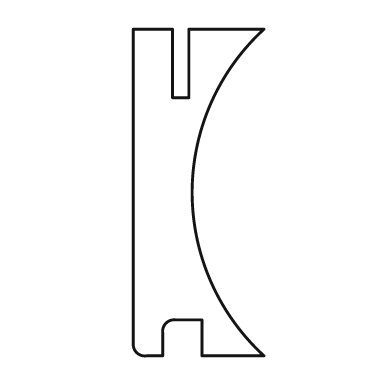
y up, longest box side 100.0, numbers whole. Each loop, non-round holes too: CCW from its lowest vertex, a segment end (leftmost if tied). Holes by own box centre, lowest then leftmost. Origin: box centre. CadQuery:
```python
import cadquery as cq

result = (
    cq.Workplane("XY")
    .moveTo(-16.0, -50.0)
    .lineTo(-11.0, -50.0)
    .lineTo(-11.0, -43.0)
    .threePointArc((-10.0, -40.0), (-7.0, -39.0))
    .lineTo(1.0, -39.0)
    .lineTo(1.0, -50.0)
    .lineTo(20.0, -50.0)
    .threePointArc((-2.0, 0.0), (20.0, 50.0))
    .lineTo(-3.0, 50.0)
    .lineTo(-3.0, 29.0)
    .lineTo(-8.0, 29.0)
    .lineTo(-8.0, 50.0)
    .lineTo(-20.0, 50.0)
    .lineTo(-20.0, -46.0)
    .threePointArc((-19.0, -49.0), (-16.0, -50.0))
    .close()
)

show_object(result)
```